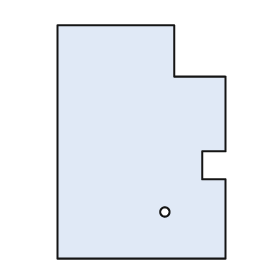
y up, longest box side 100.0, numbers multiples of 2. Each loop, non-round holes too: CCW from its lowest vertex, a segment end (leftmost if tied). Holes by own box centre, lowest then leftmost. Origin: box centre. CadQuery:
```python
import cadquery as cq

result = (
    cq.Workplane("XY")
    .moveTo(-36.0, -50.0)
    .lineTo(36.0, -50.0)
    .lineTo(36.0, -16.0)
    .lineTo(26.0, -16.0)
    .lineTo(26.0, -4.0)
    .lineTo(36.0, -4.0)
    .lineTo(36.0, 28.0)
    .lineTo(14.0, 28.0)
    .lineTo(14.0, 50.0)
    .lineTo(-36.0, 50.0)
    .close()
    .moveTo(10.0, -30.0)
    .circle(2.0)
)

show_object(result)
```